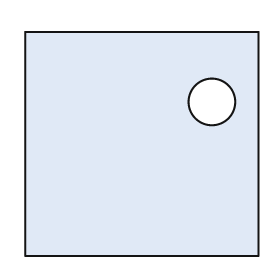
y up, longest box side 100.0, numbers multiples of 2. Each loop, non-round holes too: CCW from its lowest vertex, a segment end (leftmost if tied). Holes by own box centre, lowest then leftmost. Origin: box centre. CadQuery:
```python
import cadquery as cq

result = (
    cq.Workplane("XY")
    .moveTo(-50.0, -48.0)
    .lineTo(50.0, -48.0)
    .lineTo(50.0, 48.0)
    .lineTo(-50.0, 48.0)
    .close()
    .moveTo(30.0, 18.0)
    .circle(10.0)
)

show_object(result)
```